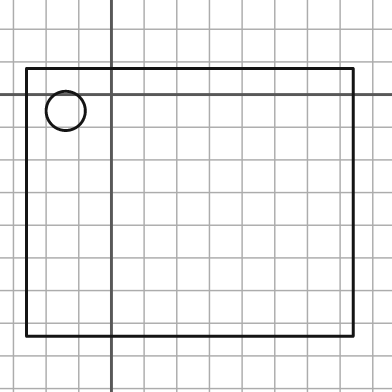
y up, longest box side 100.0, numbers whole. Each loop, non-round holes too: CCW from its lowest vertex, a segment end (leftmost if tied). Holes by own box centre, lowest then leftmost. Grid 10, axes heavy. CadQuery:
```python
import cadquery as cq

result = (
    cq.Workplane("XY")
    .moveTo(-26.0, -74.0)
    .lineTo(74.0, -74.0)
    .lineTo(74.0, 8.0)
    .lineTo(-26.0, 8.0)
    .close()
    .moveTo(-14.0, -5.0)
    .circle(6.0)
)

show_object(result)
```